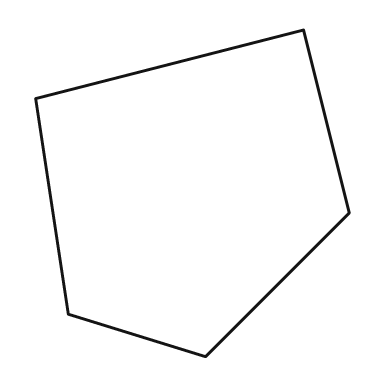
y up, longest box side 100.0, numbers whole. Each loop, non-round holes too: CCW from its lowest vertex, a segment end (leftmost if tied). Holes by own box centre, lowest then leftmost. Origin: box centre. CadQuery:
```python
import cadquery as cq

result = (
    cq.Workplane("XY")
    .moveTo(4.0, -50.0)
    .lineTo(48.0, -6.0)
    .lineTo(34.0, 50.0)
    .lineTo(-48.0, 29.0)
    .lineTo(-38.0, -37.0)
    .close()
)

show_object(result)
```